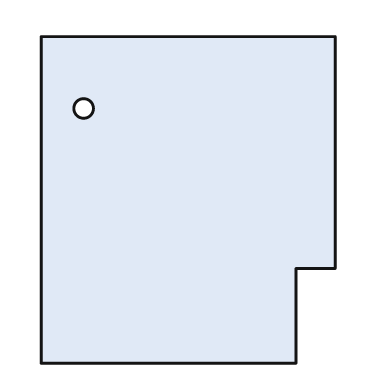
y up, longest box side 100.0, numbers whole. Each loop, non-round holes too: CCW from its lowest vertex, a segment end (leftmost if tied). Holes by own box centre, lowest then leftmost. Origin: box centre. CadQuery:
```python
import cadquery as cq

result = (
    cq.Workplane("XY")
    .moveTo(-45.0, -50.0)
    .lineTo(33.0, -50.0)
    .lineTo(33.0, -21.0)
    .lineTo(45.0, -21.0)
    .lineTo(45.0, 50.0)
    .lineTo(-45.0, 50.0)
    .close()
    .moveTo(-32.0, 28.0)
    .circle(3.0)
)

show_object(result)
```